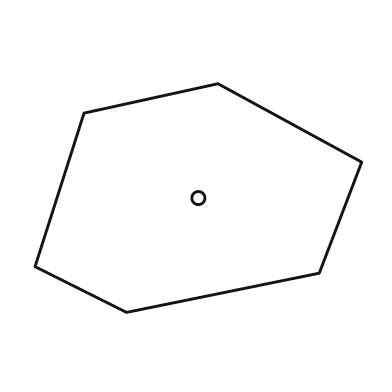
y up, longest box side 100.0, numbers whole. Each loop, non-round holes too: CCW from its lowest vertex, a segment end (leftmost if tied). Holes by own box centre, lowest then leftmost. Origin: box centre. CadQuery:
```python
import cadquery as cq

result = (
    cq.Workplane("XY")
    .moveTo(-22.0, -35.0)
    .lineTo(37.0, -23.0)
    .lineTo(50.0, 11.0)
    .lineTo(6.0, 35.0)
    .lineTo(-35.0, 26.0)
    .lineTo(-50.0, -21.0)
    .close()
    .moveTo(0.0, 0.0)
    .circle(2.0)
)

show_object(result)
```